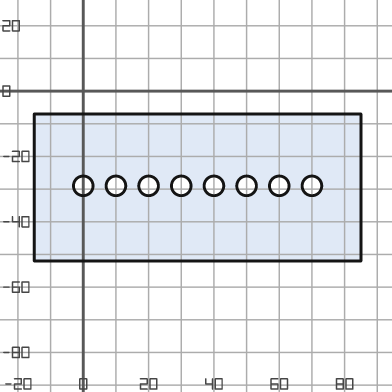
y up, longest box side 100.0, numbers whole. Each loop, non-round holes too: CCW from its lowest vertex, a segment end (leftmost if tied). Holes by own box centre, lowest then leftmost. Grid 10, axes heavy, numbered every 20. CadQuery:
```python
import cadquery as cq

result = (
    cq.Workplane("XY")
    .moveTo(-15.0, -52.0)
    .lineTo(85.0, -52.0)
    .lineTo(85.0, -7.0)
    .lineTo(-15.0, -7.0)
    .close()
    .moveTo(0.0, -29.0)
    .circle(3.0)
    .moveTo(10.0, -29.0)
    .circle(3.0)
    .moveTo(20.0, -29.0)
    .circle(3.0)
    .moveTo(30.0, -29.0)
    .circle(3.0)
    .moveTo(40.0, -29.0)
    .circle(3.0)
    .moveTo(50.0, -29.0)
    .circle(3.0)
    .moveTo(60.0, -29.0)
    .circle(3.0)
    .moveTo(70.0, -29.0)
    .circle(3.0)
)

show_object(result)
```